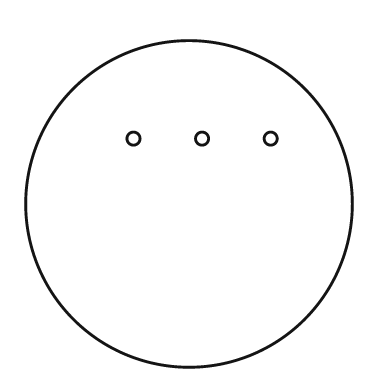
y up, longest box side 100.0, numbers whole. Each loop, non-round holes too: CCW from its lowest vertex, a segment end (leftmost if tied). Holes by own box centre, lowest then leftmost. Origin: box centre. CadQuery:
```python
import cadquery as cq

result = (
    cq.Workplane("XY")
    .moveTo(0.0, 0.0)
    .circle(50.0)
    .moveTo(-17.0, 20.0)
    .circle(2.0)
    .moveTo(4.0, 20.0)
    .circle(2.0)
    .moveTo(25.0, 20.0)
    .circle(2.0)
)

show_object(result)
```